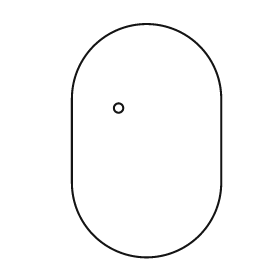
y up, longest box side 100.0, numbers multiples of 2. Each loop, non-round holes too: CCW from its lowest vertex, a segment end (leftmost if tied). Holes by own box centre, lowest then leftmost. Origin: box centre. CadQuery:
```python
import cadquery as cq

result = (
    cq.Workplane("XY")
    .moveTo(-32.0, -18.0)
    .threePointArc((0.0, -50.0), (32.0, -18.0))
    .lineTo(32.0, 18.0)
    .threePointArc((0.0, 50.0), (-32.0, 18.0))
    .close()
    .moveTo(-12.0, 14.0)
    .circle(2.0)
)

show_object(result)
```